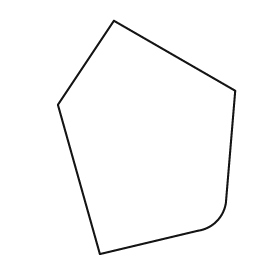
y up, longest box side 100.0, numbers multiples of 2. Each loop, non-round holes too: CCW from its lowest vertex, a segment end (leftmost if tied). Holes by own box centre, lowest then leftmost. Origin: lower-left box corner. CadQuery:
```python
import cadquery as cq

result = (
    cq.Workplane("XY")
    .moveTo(18.0, 0.0)
    .lineTo(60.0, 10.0)
    .threePointArc((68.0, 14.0), (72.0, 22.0))
    .lineTo(76.0, 70.0)
    .lineTo(24.0, 100.0)
    .lineTo(0.0, 64.0)
    .close()
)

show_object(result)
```